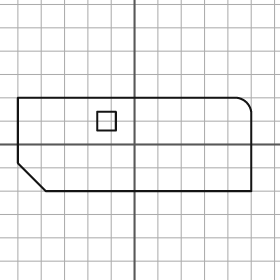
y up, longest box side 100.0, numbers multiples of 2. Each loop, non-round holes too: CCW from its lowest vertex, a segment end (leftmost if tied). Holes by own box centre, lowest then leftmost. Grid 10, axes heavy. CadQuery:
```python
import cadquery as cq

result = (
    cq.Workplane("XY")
    .moveTo(-38.0, -20.0)
    .lineTo(50.0, -20.0)
    .lineTo(50.0, 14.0)
    .threePointArc((48.0, 18.0), (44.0, 20.0))
    .lineTo(-50.0, 20.0)
    .lineTo(-50.0, -8.0)
    .close()
    .moveTo(-16.0, 6.0)
    .lineTo(-8.0, 6.0)
    .lineTo(-8.0, 14.0)
    .lineTo(-16.0, 14.0)
    .close()
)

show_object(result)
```